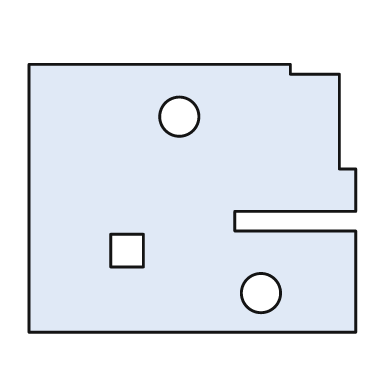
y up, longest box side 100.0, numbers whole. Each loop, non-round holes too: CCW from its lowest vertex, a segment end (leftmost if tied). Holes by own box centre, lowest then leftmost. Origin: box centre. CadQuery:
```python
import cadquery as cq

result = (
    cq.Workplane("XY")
    .moveTo(-50.0, -41.0)
    .lineTo(50.0, -41.0)
    .lineTo(50.0, -10.0)
    .lineTo(13.0, -10.0)
    .lineTo(13.0, -4.0)
    .lineTo(50.0, -4.0)
    .lineTo(50.0, 9.0)
    .lineTo(45.0, 9.0)
    .lineTo(45.0, 38.0)
    .lineTo(30.0, 38.0)
    .lineTo(30.0, 41.0)
    .lineTo(-50.0, 41.0)
    .close()
    .moveTo(21.0, -29.0)
    .circle(6.0)
    .moveTo(-25.0, -21.0)
    .lineTo(-15.0, -21.0)
    .lineTo(-15.0, -11.0)
    .lineTo(-25.0, -11.0)
    .close()
    .moveTo(-4.0, 25.0)
    .circle(6.0)
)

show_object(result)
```